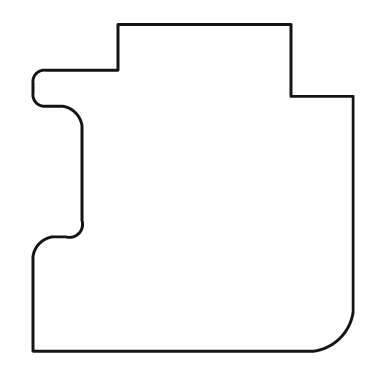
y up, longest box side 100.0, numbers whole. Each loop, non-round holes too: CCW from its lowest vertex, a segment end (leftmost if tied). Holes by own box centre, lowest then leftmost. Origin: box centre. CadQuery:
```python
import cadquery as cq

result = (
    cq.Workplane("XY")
    .moveTo(-49.0, -50.0)
    .lineTo(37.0, -50.0)
    .threePointArc((45.0, -46.0), (49.0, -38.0))
    .lineTo(49.0, 28.0)
    .lineTo(30.0, 28.0)
    .lineTo(30.0, 50.0)
    .lineTo(-23.0, 50.0)
    .lineTo(-23.0, 36.0)
    .lineTo(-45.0, 36.0)
    .threePointArc((-48.0, 35.0), (-49.0, 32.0))
    .lineTo(-49.0, 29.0)
    .threePointArc((-48.0, 26.0), (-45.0, 25.0))
    .lineTo(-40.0, 25.0)
    .threePointArc((-36.0, 23.0), (-34.0, 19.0))
    .lineTo(-34.0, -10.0)
    .threePointArc((-35.0, -14.0), (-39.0, -15.0))
    .lineTo(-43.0, -15.0)
    .threePointArc((-47.0, -17.0), (-49.0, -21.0))
    .close()
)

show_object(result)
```